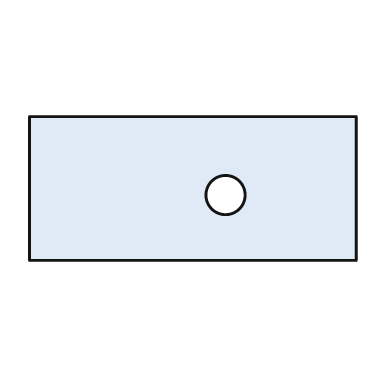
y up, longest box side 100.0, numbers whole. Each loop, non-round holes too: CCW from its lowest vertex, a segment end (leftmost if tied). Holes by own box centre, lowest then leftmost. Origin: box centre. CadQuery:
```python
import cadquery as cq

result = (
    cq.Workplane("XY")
    .moveTo(-50.0, -22.0)
    .lineTo(50.0, -22.0)
    .lineTo(50.0, 22.0)
    .lineTo(-50.0, 22.0)
    .close()
    .moveTo(10.0, -2.0)
    .circle(6.0)
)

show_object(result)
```